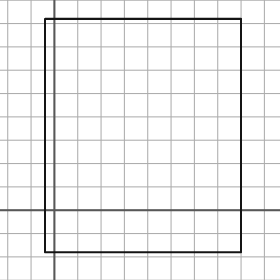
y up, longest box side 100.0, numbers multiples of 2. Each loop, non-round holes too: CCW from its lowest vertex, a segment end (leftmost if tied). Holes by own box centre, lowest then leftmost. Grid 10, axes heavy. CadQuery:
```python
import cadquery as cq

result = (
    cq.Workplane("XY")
    .moveTo(-4.0, -18.0)
    .lineTo(80.0, -18.0)
    .lineTo(80.0, 82.0)
    .lineTo(-4.0, 82.0)
    .close()
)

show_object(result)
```